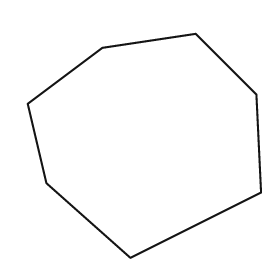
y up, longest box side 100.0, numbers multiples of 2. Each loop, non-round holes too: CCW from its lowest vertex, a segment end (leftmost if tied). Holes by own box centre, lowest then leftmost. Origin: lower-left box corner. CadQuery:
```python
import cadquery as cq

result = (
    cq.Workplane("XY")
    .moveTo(44.0, 0.0)
    .lineTo(100.0, 28.0)
    .lineTo(98.0, 70.0)
    .lineTo(72.0, 96.0)
    .lineTo(32.0, 90.0)
    .lineTo(0.0, 66.0)
    .lineTo(8.0, 32.0)
    .close()
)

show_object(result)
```